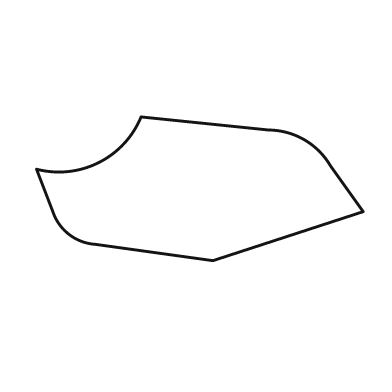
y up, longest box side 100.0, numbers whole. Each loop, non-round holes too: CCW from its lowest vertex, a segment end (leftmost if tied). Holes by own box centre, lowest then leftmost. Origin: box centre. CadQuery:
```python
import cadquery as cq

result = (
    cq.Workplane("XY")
    .moveTo(4.0, -22.0)
    .lineTo(50.0, -7.0)
    .lineTo(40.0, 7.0)
    .threePointArc((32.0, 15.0), (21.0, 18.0))
    .lineTo(-18.0, 22.0)
    .threePointArc((-31.0, 8.0), (-50.0, 6.0))
    .lineTo(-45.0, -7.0)
    .threePointArc((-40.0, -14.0), (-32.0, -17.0))
    .close()
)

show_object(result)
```